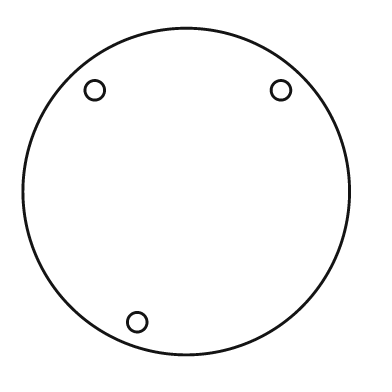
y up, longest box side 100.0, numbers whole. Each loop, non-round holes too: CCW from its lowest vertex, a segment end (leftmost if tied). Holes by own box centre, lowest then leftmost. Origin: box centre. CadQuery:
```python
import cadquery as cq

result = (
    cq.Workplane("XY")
    .moveTo(0.0, 0.0)
    .circle(50.0)
    .moveTo(-15.0, -40.0)
    .circle(3.0)
    .moveTo(-28.0, 31.0)
    .circle(3.0)
    .moveTo(29.0, 31.0)
    .circle(3.0)
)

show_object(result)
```